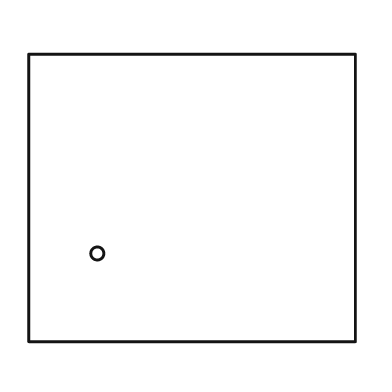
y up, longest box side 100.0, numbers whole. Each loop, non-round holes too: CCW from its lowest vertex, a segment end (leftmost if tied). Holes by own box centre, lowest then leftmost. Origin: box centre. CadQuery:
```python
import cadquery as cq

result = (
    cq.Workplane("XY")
    .moveTo(-50.0, -44.0)
    .lineTo(50.0, -44.0)
    .lineTo(50.0, 44.0)
    .lineTo(-50.0, 44.0)
    .close()
    .moveTo(-29.0, -17.0)
    .circle(2.0)
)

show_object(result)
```